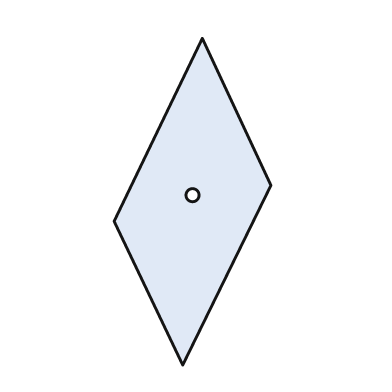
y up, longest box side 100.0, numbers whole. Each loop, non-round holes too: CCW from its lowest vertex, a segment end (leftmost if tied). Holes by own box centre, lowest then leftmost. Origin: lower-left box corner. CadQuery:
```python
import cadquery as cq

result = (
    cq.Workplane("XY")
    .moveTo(21.0, 0.0)
    .lineTo(48.0, 55.0)
    .lineTo(27.0, 100.0)
    .lineTo(0.0, 44.0)
    .close()
    .moveTo(24.0, 52.0)
    .circle(2.0)
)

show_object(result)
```